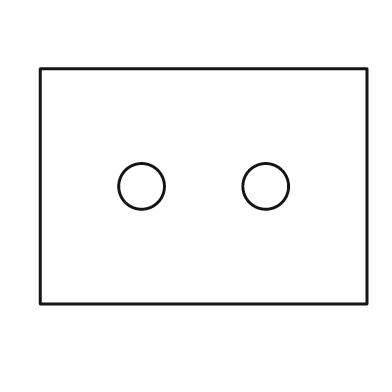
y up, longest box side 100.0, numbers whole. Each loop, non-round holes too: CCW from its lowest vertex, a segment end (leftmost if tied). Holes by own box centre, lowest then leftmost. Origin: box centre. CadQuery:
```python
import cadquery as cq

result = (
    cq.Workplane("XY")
    .moveTo(-50.0, -36.0)
    .lineTo(50.0, -36.0)
    .lineTo(50.0, 36.0)
    .lineTo(-50.0, 36.0)
    .close()
    .moveTo(-19.0, 0.0)
    .circle(7.0)
    .moveTo(19.0, 0.0)
    .circle(7.0)
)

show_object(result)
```